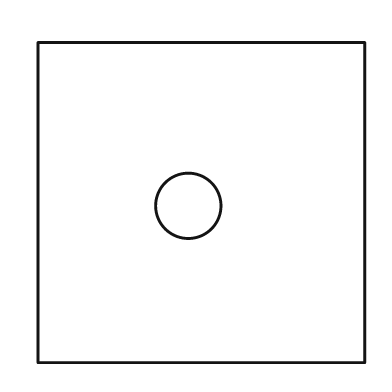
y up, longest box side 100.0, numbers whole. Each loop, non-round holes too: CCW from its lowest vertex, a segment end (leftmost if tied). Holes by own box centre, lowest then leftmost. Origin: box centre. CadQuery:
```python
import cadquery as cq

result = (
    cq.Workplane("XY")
    .moveTo(-50.0, -49.0)
    .lineTo(50.0, -49.0)
    .lineTo(50.0, 49.0)
    .lineTo(-50.0, 49.0)
    .close()
    .moveTo(-4.0, -1.0)
    .circle(10.0)
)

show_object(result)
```